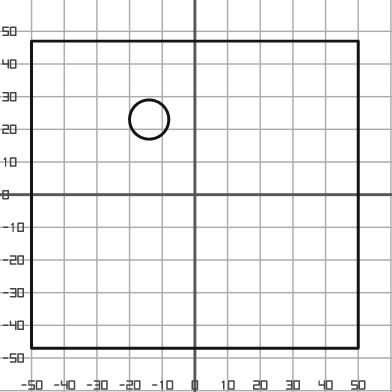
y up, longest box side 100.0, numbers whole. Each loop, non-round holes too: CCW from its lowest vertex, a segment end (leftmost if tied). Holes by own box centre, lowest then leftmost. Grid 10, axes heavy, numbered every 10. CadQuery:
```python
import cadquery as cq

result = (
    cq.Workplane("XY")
    .moveTo(-50.0, -47.0)
    .lineTo(50.0, -47.0)
    .lineTo(50.0, 47.0)
    .lineTo(-50.0, 47.0)
    .close()
    .moveTo(-14.0, 23.0)
    .circle(6.0)
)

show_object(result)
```